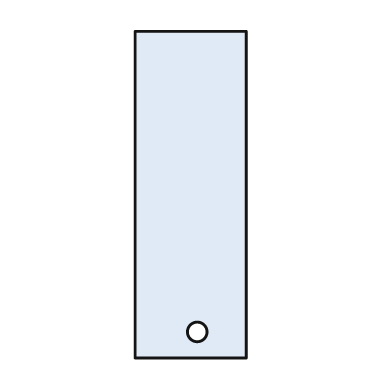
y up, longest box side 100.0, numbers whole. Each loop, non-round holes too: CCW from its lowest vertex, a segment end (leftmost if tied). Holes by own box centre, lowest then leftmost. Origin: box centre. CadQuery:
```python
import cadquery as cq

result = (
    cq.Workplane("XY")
    .moveTo(-17.0, -50.0)
    .lineTo(17.0, -50.0)
    .lineTo(17.0, 50.0)
    .lineTo(-17.0, 50.0)
    .close()
    .moveTo(2.0, -42.0)
    .circle(3.0)
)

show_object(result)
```